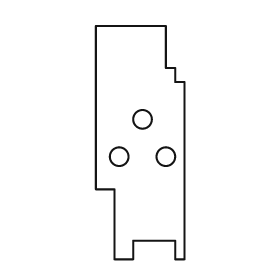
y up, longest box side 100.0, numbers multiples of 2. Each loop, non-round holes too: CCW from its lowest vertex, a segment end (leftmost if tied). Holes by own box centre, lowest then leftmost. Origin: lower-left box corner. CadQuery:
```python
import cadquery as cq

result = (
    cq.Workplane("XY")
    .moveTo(8.0, 0.0)
    .lineTo(16.0, 0.0)
    .lineTo(16.0, 8.0)
    .lineTo(34.0, 8.0)
    .lineTo(34.0, 0.0)
    .lineTo(38.0, 0.0)
    .lineTo(38.0, 76.0)
    .lineTo(34.0, 76.0)
    .lineTo(34.0, 82.0)
    .lineTo(30.0, 82.0)
    .lineTo(30.0, 100.0)
    .lineTo(0.0, 100.0)
    .lineTo(0.0, 30.0)
    .lineTo(8.0, 30.0)
    .close()
    .moveTo(10.0, 44.0)
    .circle(4.0)
    .moveTo(30.0, 44.0)
    .circle(4.0)
    .moveTo(20.0, 60.0)
    .circle(4.0)
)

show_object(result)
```